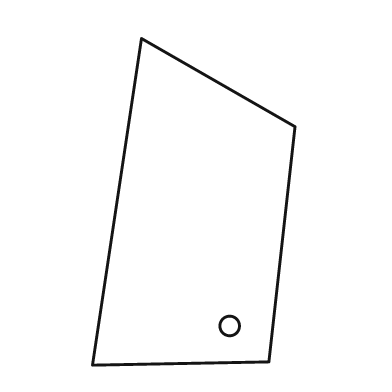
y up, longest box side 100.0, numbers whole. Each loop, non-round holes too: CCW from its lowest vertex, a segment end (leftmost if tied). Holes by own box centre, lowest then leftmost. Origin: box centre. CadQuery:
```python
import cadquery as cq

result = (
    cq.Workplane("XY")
    .moveTo(-31.0, -50.0)
    .lineTo(23.0, -49.0)
    .lineTo(31.0, 23.0)
    .lineTo(-16.0, 50.0)
    .close()
    .moveTo(11.0, -38.0)
    .circle(3.0)
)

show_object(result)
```